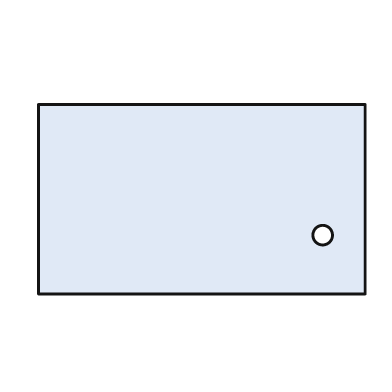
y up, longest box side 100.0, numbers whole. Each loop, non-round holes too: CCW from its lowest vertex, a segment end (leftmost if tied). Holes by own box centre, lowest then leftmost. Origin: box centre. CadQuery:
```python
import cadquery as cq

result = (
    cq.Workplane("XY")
    .moveTo(-50.0, -29.0)
    .lineTo(50.0, -29.0)
    .lineTo(50.0, 29.0)
    .lineTo(-50.0, 29.0)
    .close()
    .moveTo(37.0, -11.0)
    .circle(3.0)
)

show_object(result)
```